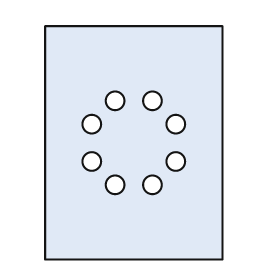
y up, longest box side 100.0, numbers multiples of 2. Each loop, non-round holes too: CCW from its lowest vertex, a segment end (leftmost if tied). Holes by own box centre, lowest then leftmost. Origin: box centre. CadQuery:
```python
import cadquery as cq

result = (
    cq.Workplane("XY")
    .moveTo(-38.0, -50.0)
    .lineTo(38.0, -50.0)
    .lineTo(38.0, 50.0)
    .lineTo(-38.0, 50.0)
    .close()
    .moveTo(-8.0, -18.0)
    .circle(4.0)
    .moveTo(8.0, -18.0)
    .circle(4.0)
    .moveTo(-18.0, -8.0)
    .circle(4.0)
    .moveTo(18.0, -8.0)
    .circle(4.0)
    .moveTo(-18.0, 8.0)
    .circle(4.0)
    .moveTo(18.0, 8.0)
    .circle(4.0)
    .moveTo(-8.0, 18.0)
    .circle(4.0)
    .moveTo(8.0, 18.0)
    .circle(4.0)
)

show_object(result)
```